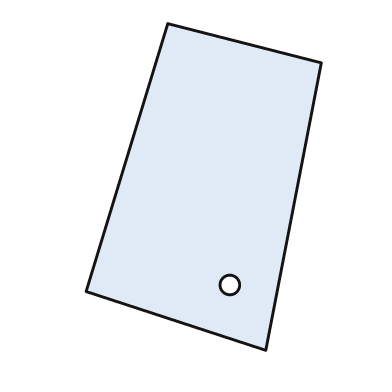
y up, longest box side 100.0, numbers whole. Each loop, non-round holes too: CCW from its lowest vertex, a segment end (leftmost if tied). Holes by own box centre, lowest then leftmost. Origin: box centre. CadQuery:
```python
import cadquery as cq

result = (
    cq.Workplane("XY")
    .moveTo(19.0, -50.0)
    .lineTo(36.0, 38.0)
    .lineTo(-11.0, 50.0)
    .lineTo(-36.0, -32.0)
    .close()
    .moveTo(8.0, -30.0)
    .circle(3.0)
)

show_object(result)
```